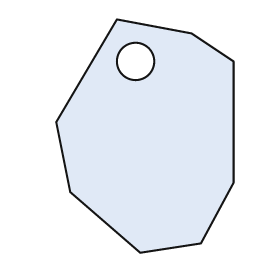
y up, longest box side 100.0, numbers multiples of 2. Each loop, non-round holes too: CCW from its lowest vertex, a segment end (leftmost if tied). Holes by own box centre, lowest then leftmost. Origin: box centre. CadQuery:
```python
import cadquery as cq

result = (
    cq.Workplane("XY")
    .moveTo(-2.0, -50.0)
    .lineTo(24.0, -46.0)
    .lineTo(38.0, -20.0)
    .lineTo(38.0, 32.0)
    .lineTo(20.0, 44.0)
    .lineTo(-12.0, 50.0)
    .lineTo(-38.0, 6.0)
    .lineTo(-32.0, -24.0)
    .close()
    .moveTo(-4.0, 32.0)
    .circle(8.0)
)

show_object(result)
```